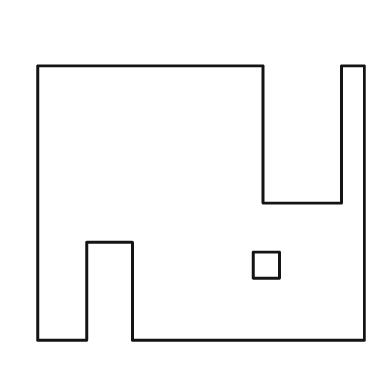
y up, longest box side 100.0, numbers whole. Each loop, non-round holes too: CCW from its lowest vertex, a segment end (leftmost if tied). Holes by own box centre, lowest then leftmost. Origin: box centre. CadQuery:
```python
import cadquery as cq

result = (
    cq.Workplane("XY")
    .moveTo(-50.0, -42.0)
    .lineTo(-35.0, -42.0)
    .lineTo(-35.0, -12.0)
    .lineTo(-21.0, -12.0)
    .lineTo(-21.0, -42.0)
    .lineTo(50.0, -42.0)
    .lineTo(50.0, 42.0)
    .lineTo(43.0, 42.0)
    .lineTo(43.0, 0.0)
    .lineTo(19.0, 0.0)
    .lineTo(19.0, 42.0)
    .lineTo(-50.0, 42.0)
    .close()
    .moveTo(16.0, -23.0)
    .lineTo(24.0, -23.0)
    .lineTo(24.0, -15.0)
    .lineTo(16.0, -15.0)
    .close()
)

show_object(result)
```